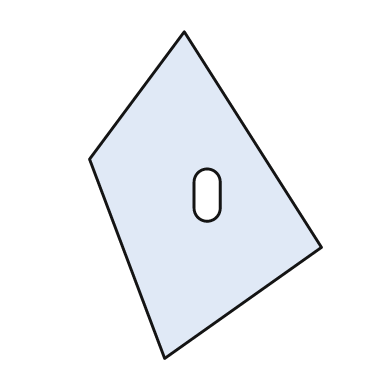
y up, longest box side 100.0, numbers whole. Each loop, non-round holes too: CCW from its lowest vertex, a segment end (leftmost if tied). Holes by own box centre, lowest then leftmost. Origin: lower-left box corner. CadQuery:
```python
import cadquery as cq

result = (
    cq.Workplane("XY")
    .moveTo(23.0, 0.0)
    .lineTo(71.0, 34.0)
    .lineTo(29.0, 100.0)
    .lineTo(0.0, 61.0)
    .close()
    .moveTo(32.0, 46.0)
    .threePointArc((36.0, 42.0), (40.0, 46.0))
    .lineTo(40.0, 54.0)
    .threePointArc((36.0, 58.0), (32.0, 54.0))
    .close()
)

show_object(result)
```